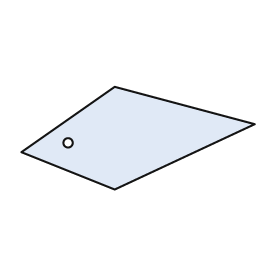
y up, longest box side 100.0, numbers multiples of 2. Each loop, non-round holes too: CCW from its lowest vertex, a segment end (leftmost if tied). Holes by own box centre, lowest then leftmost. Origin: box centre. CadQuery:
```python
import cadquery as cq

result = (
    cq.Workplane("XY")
    .moveTo(-10.0, -22.0)
    .lineTo(50.0, 6.0)
    .lineTo(-10.0, 22.0)
    .lineTo(-50.0, -6.0)
    .close()
    .moveTo(-30.0, -2.0)
    .circle(2.0)
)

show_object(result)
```